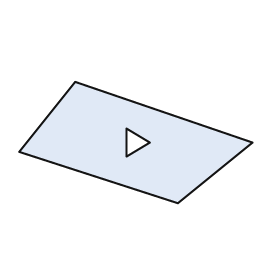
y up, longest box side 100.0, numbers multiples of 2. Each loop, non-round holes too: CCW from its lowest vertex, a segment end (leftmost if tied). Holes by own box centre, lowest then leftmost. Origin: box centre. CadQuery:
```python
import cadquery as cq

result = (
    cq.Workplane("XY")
    .moveTo(18.0, -26.0)
    .lineTo(50.0, 0.0)
    .lineTo(-26.0, 26.0)
    .lineTo(-50.0, -4.0)
    .close()
    .moveTo(-4.0, -6.0)
    .lineTo(6.0, 0.0)
    .lineTo(-4.0, 6.0)
    .close()
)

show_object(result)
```